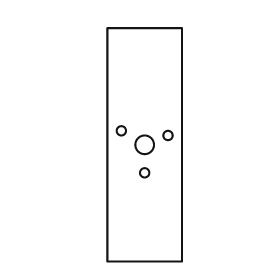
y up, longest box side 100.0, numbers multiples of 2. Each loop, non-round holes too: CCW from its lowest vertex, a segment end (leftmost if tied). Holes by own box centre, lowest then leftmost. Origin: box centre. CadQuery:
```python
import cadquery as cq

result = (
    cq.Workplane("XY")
    .moveTo(-16.0, -50.0)
    .lineTo(16.0, -50.0)
    .lineTo(16.0, 50.0)
    .lineTo(-16.0, 50.0)
    .close()
    .moveTo(0.0, -12.0)
    .circle(2.0)
    .moveTo(0.0, 0.0)
    .circle(4.0)
    .moveTo(10.0, 4.0)
    .circle(2.0)
    .moveTo(-10.0, 6.0)
    .circle(2.0)
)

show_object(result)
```